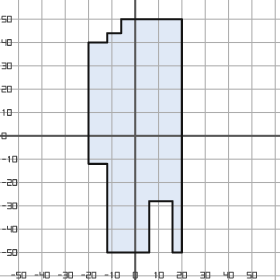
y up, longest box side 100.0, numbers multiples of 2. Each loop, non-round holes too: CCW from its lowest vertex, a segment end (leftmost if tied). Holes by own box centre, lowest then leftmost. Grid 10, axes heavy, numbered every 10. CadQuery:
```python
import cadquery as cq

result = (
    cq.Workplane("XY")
    .moveTo(-12.0, -50.0)
    .lineTo(6.0, -50.0)
    .lineTo(6.0, -28.0)
    .lineTo(16.0, -28.0)
    .lineTo(16.0, -50.0)
    .lineTo(20.0, -50.0)
    .lineTo(20.0, 50.0)
    .lineTo(-6.0, 50.0)
    .lineTo(-6.0, 44.0)
    .lineTo(-12.0, 44.0)
    .lineTo(-12.0, 40.0)
    .lineTo(-20.0, 40.0)
    .lineTo(-20.0, -12.0)
    .lineTo(-12.0, -12.0)
    .close()
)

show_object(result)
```